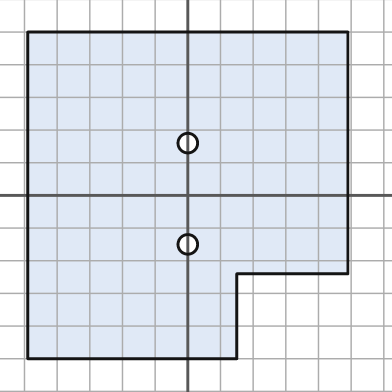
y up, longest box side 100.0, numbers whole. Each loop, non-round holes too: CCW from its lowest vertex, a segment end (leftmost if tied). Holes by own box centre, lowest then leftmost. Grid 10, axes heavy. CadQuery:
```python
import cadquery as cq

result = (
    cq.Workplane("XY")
    .moveTo(-49.0, -50.0)
    .lineTo(15.0, -50.0)
    .lineTo(15.0, -24.0)
    .lineTo(49.0, -24.0)
    .lineTo(49.0, 50.0)
    .lineTo(-49.0, 50.0)
    .close()
    .moveTo(0.0, -15.0)
    .circle(3.0)
    .moveTo(0.0, 16.0)
    .circle(3.0)
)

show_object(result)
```